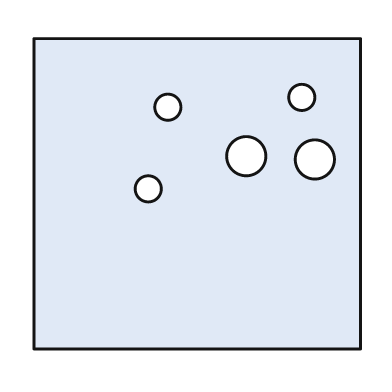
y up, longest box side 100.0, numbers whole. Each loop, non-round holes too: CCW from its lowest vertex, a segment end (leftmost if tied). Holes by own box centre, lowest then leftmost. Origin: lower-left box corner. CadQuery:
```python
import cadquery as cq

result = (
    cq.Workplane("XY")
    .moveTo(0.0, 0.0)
    .lineTo(100.0, 0.0)
    .lineTo(100.0, 95.0)
    .lineTo(0.0, 95.0)
    .close()
    .moveTo(35.0, 49.0)
    .circle(4.0)
    .moveTo(86.0, 58.0)
    .circle(6.0)
    .moveTo(65.0, 59.0)
    .circle(6.0)
    .moveTo(41.0, 74.0)
    .circle(4.0)
    .moveTo(82.0, 77.0)
    .circle(4.0)
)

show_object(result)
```